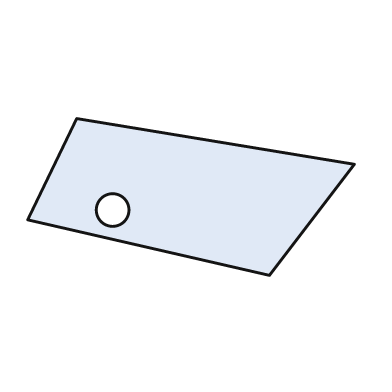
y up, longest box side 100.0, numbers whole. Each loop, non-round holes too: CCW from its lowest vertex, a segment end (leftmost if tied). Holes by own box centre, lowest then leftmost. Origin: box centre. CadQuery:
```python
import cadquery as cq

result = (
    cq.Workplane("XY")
    .moveTo(24.0, -24.0)
    .lineTo(50.0, 10.0)
    .lineTo(-35.0, 24.0)
    .lineTo(-50.0, -7.0)
    .close()
    .moveTo(-24.0, -4.0)
    .circle(5.0)
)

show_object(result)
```